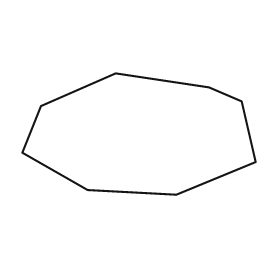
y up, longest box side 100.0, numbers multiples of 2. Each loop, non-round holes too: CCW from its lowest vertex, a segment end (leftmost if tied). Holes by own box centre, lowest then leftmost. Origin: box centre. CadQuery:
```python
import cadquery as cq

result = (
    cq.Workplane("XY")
    .moveTo(16.0, -26.0)
    .lineTo(50.0, -12.0)
    .lineTo(44.0, 14.0)
    .lineTo(30.0, 20.0)
    .lineTo(-10.0, 26.0)
    .lineTo(-42.0, 12.0)
    .lineTo(-50.0, -8.0)
    .lineTo(-22.0, -24.0)
    .close()
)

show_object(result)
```